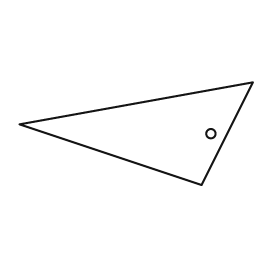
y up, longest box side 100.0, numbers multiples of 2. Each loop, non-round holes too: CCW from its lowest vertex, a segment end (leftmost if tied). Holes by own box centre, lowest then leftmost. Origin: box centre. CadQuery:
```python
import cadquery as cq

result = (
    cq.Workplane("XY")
    .moveTo(28.0, -22.0)
    .lineTo(50.0, 22.0)
    .lineTo(-50.0, 4.0)
    .close()
    .moveTo(32.0, 0.0)
    .circle(2.0)
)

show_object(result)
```